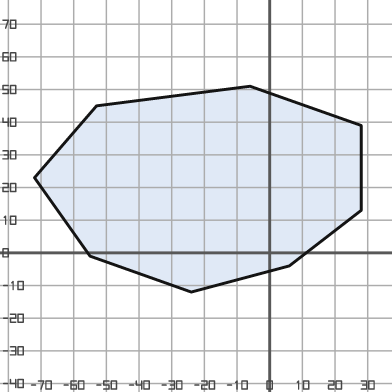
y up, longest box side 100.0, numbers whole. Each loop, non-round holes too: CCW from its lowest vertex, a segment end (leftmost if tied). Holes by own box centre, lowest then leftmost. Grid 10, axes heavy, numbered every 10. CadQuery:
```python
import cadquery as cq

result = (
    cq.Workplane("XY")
    .moveTo(-24.0, -12.0)
    .lineTo(6.0, -4.0)
    .lineTo(28.0, 13.0)
    .lineTo(28.0, 39.0)
    .lineTo(-6.0, 51.0)
    .lineTo(-53.0, 45.0)
    .lineTo(-72.0, 23.0)
    .lineTo(-55.0, -1.0)
    .close()
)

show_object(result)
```